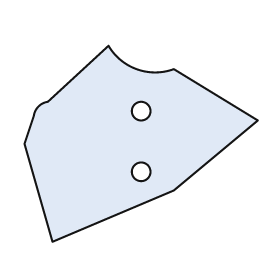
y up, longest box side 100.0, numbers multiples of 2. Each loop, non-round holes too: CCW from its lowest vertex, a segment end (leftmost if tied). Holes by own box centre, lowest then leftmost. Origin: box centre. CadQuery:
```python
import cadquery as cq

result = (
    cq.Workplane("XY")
    .moveTo(-38.0, -42.0)
    .lineTo(14.0, -20.0)
    .lineTo(50.0, 10.0)
    .lineTo(14.0, 32.0)
    .threePointArc((-2.0, 32.0), (-14.0, 42.0))
    .lineTo(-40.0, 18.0)
    .threePointArc((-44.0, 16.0), (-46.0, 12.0))
    .lineTo(-50.0, 0.0)
    .close()
    .moveTo(0.0, -12.0)
    .circle(4.0)
    .moveTo(0.0, 14.0)
    .circle(4.0)
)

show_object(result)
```